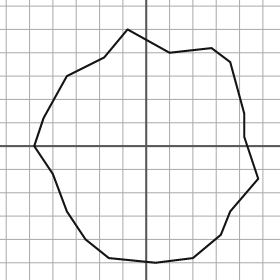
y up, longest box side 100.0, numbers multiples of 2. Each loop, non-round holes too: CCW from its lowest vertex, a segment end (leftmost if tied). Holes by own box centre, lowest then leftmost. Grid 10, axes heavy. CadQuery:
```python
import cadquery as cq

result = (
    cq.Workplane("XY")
    .moveTo(4.0, -50.0)
    .lineTo(20.0, -48.0)
    .lineTo(32.0, -38.0)
    .lineTo(36.0, -28.0)
    .lineTo(48.0, -14.0)
    .lineTo(42.0, 4.0)
    .lineTo(42.0, 14.0)
    .lineTo(36.0, 36.0)
    .lineTo(28.0, 42.0)
    .lineTo(10.0, 40.0)
    .lineTo(-8.0, 50.0)
    .lineTo(-18.0, 38.0)
    .lineTo(-34.0, 30.0)
    .lineTo(-44.0, 12.0)
    .lineTo(-48.0, 0.0)
    .lineTo(-40.0, -12.0)
    .lineTo(-34.0, -28.0)
    .lineTo(-26.0, -40.0)
    .lineTo(-16.0, -48.0)
    .close()
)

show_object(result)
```